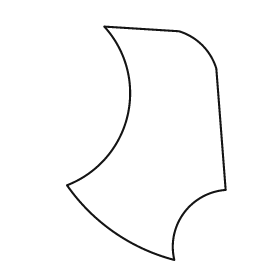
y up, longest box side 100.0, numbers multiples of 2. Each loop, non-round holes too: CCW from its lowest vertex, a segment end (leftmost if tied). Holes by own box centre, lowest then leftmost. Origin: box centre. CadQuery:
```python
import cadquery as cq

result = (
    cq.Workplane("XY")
    .moveTo(12.0, -50.0)
    .threePointArc((16.0, -30.0), (34.0, -20.0))
    .lineTo(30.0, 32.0)
    .threePointArc((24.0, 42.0), (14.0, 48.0))
    .lineTo(-18.0, 50.0)
    .threePointArc((-8.0, 12.0), (-34.0, -18.0))
    .threePointArc((-14.0, -38.0), (12.0, -50.0))
    .close()
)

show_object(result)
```